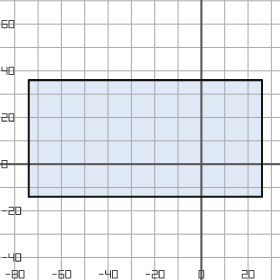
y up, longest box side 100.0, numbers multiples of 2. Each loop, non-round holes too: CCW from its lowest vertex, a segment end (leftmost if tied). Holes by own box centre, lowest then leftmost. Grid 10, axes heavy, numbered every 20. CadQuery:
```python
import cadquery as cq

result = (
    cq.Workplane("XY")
    .moveTo(-74.0, -14.0)
    .lineTo(26.0, -14.0)
    .lineTo(26.0, 36.0)
    .lineTo(-74.0, 36.0)
    .close()
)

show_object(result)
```